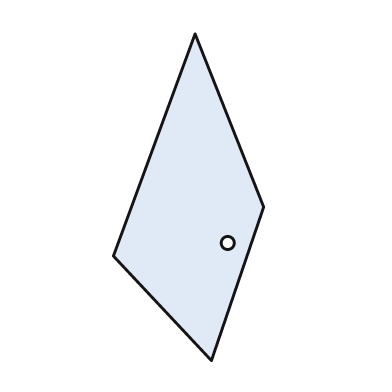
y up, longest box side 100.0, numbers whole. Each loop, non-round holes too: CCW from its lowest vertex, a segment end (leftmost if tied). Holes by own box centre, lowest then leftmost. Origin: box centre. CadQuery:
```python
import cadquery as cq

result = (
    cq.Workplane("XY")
    .moveTo(7.0, -50.0)
    .lineTo(23.0, -3.0)
    .lineTo(2.0, 50.0)
    .lineTo(-23.0, -18.0)
    .close()
    .moveTo(12.0, -14.0)
    .circle(2.0)
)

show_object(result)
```